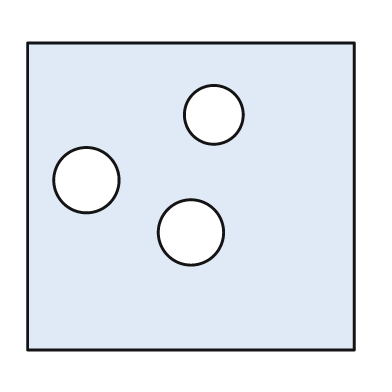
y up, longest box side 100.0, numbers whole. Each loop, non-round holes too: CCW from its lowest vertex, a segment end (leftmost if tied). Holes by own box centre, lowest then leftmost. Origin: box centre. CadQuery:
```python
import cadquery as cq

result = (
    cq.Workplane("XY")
    .moveTo(-50.0, -47.0)
    .lineTo(50.0, -47.0)
    .lineTo(50.0, 47.0)
    .lineTo(-50.0, 47.0)
    .close()
    .moveTo(0.0, -11.0)
    .circle(10.0)
    .moveTo(-32.0, 5.0)
    .circle(10.0)
    .moveTo(7.0, 25.0)
    .circle(9.0)
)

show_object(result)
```